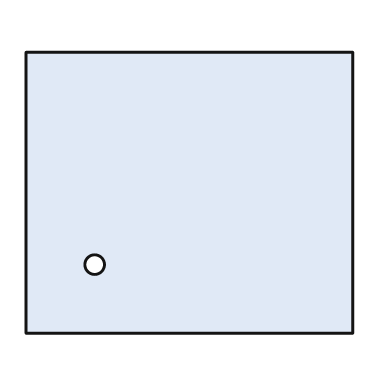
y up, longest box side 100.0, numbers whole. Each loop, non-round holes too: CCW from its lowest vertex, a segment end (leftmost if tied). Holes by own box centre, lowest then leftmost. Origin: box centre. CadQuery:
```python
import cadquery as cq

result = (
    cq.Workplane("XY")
    .moveTo(-50.0, -43.0)
    .lineTo(50.0, -43.0)
    .lineTo(50.0, 43.0)
    .lineTo(-50.0, 43.0)
    .close()
    .moveTo(-29.0, -22.0)
    .circle(3.0)
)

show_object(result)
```